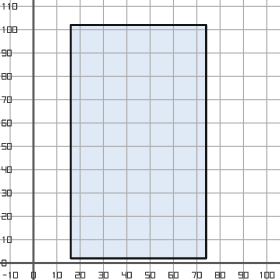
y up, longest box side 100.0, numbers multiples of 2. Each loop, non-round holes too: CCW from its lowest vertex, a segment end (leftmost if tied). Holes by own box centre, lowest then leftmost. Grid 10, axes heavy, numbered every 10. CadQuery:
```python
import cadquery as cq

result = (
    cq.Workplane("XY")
    .moveTo(16.0, 2.0)
    .lineTo(74.0, 2.0)
    .lineTo(74.0, 102.0)
    .lineTo(16.0, 102.0)
    .close()
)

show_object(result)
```